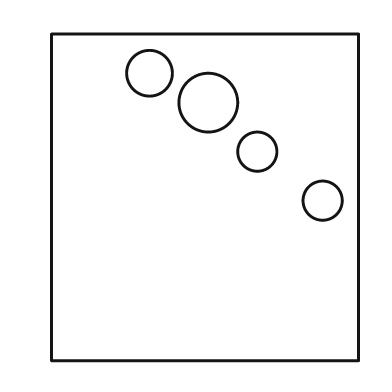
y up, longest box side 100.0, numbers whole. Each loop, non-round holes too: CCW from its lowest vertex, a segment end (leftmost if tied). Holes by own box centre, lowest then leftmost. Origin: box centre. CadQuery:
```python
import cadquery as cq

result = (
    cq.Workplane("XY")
    .moveTo(-47.0, -50.0)
    .lineTo(47.0, -50.0)
    .lineTo(47.0, 50.0)
    .lineTo(-47.0, 50.0)
    .close()
    .moveTo(36.0, -1.0)
    .circle(6.0)
    .moveTo(16.0, 14.0)
    .circle(6.0)
    .moveTo(1.0, 29.0)
    .circle(9.0)
    .moveTo(-17.0, 38.0)
    .circle(7.0)
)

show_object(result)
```